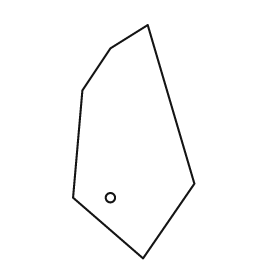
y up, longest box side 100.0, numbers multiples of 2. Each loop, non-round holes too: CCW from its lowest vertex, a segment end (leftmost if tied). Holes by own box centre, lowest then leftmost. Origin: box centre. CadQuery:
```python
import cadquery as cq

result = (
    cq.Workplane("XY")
    .moveTo(4.0, -50.0)
    .lineTo(26.0, -18.0)
    .lineTo(6.0, 50.0)
    .lineTo(-10.0, 40.0)
    .lineTo(-22.0, 22.0)
    .lineTo(-26.0, -24.0)
    .close()
    .moveTo(-10.0, -24.0)
    .circle(2.0)
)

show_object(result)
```